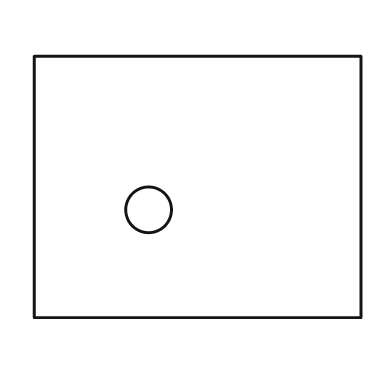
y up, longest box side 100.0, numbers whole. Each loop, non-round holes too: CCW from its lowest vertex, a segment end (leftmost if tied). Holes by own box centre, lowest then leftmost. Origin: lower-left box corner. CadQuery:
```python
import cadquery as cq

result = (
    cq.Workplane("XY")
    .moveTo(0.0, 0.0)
    .lineTo(100.0, 0.0)
    .lineTo(100.0, 80.0)
    .lineTo(0.0, 80.0)
    .close()
    .moveTo(35.0, 33.0)
    .circle(7.0)
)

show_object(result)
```